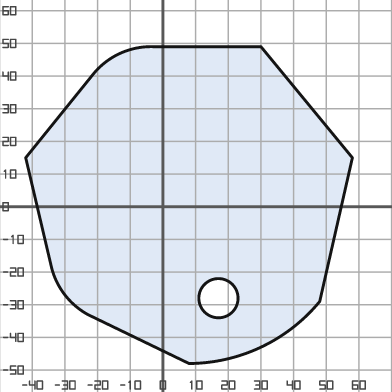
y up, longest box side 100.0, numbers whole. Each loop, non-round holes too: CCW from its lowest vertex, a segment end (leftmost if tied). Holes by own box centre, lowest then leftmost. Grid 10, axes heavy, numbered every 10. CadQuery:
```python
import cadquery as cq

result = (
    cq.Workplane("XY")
    .moveTo(8.0, -48.0)
    .threePointArc((30.0, -43.0), (48.0, -29.0))
    .lineTo(58.0, 15.0)
    .lineTo(30.0, 49.0)
    .lineTo(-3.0, 49.0)
    .threePointArc((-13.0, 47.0), (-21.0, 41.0))
    .lineTo(-42.0, 15.0)
    .lineTo(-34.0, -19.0)
    .threePointArc((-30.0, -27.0), (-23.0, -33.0))
    .close()
    .moveTo(17.0, -28.0)
    .circle(6.0)
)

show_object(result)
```